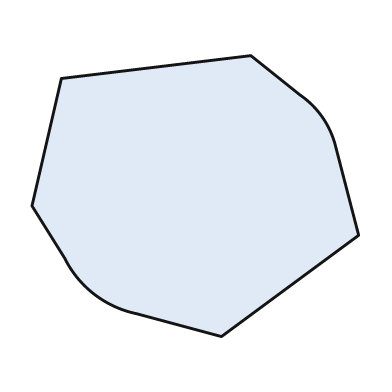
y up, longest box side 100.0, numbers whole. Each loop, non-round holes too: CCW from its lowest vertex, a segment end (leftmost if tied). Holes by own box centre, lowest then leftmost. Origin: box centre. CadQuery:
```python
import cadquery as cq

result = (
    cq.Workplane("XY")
    .moveTo(8.0, -43.0)
    .lineTo(50.0, -12.0)
    .lineTo(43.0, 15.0)
    .threePointArc((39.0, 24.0), (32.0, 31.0))
    .lineTo(17.0, 43.0)
    .lineTo(-41.0, 36.0)
    .lineTo(-50.0, -3.0)
    .lineTo(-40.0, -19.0)
    .threePointArc((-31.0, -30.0), (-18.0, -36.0))
    .close()
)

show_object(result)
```